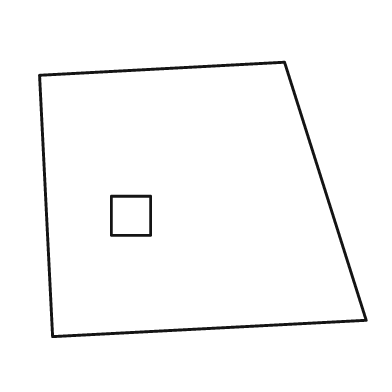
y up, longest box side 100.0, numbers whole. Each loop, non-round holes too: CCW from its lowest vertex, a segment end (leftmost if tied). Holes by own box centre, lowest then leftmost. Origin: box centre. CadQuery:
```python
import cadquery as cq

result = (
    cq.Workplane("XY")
    .moveTo(-46.0, -42.0)
    .lineTo(50.0, -37.0)
    .lineTo(25.0, 42.0)
    .lineTo(-50.0, 38.0)
    .close()
    .moveTo(-28.0, -11.0)
    .lineTo(-16.0, -11.0)
    .lineTo(-16.0, 1.0)
    .lineTo(-28.0, 1.0)
    .close()
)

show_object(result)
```